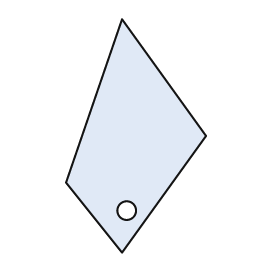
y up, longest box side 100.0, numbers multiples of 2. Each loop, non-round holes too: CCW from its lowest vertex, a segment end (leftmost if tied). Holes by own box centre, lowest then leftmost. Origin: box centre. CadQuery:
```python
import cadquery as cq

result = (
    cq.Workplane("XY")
    .moveTo(-6.0, -50.0)
    .lineTo(30.0, 0.0)
    .lineTo(-6.0, 50.0)
    .lineTo(-30.0, -20.0)
    .close()
    .moveTo(-4.0, -32.0)
    .circle(4.0)
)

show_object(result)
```